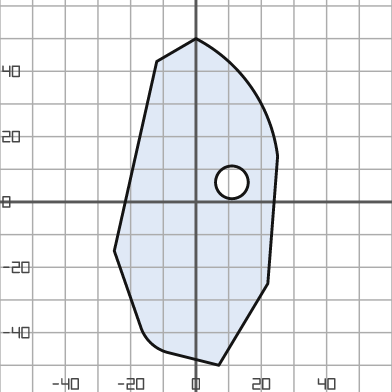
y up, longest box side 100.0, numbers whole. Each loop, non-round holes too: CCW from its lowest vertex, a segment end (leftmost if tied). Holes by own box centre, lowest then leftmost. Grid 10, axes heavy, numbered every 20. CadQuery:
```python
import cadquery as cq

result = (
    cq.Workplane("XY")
    .moveTo(7.0, -50.0)
    .lineTo(22.0, -25.0)
    .lineTo(25.0, 14.0)
    .threePointArc((17.0, 35.0), (0.0, 50.0))
    .lineTo(-12.0, 43.0)
    .lineTo(-25.0, -15.0)
    .lineTo(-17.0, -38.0)
    .threePointArc((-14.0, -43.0), (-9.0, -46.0))
    .close()
    .moveTo(11.0, 6.0)
    .circle(5.0)
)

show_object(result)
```